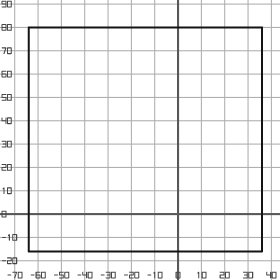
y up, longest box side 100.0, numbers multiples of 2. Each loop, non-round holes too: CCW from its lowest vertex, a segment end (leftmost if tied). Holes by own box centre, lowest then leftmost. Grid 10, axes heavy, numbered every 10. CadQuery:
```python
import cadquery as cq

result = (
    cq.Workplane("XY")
    .moveTo(-64.0, -16.0)
    .lineTo(36.0, -16.0)
    .lineTo(36.0, 80.0)
    .lineTo(-64.0, 80.0)
    .close()
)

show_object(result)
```